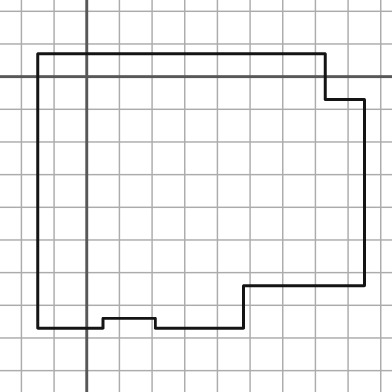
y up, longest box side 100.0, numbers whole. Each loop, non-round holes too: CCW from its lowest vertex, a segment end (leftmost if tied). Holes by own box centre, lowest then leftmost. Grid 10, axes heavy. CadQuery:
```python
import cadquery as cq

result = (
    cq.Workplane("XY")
    .moveTo(-15.0, -77.0)
    .lineTo(5.0, -77.0)
    .lineTo(5.0, -74.0)
    .lineTo(21.0, -74.0)
    .lineTo(21.0, -77.0)
    .lineTo(48.0, -77.0)
    .lineTo(48.0, -64.0)
    .lineTo(85.0, -64.0)
    .lineTo(85.0, -7.0)
    .lineTo(73.0, -7.0)
    .lineTo(73.0, 7.0)
    .lineTo(-15.0, 7.0)
    .close()
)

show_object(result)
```